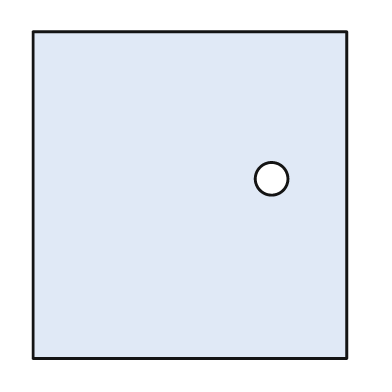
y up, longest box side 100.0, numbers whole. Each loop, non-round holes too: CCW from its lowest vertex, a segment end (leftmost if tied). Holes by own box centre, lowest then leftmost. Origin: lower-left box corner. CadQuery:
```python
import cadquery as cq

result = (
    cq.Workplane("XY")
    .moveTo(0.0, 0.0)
    .lineTo(96.0, 0.0)
    .lineTo(96.0, 100.0)
    .lineTo(0.0, 100.0)
    .close()
    .moveTo(73.0, 55.0)
    .circle(5.0)
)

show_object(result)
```